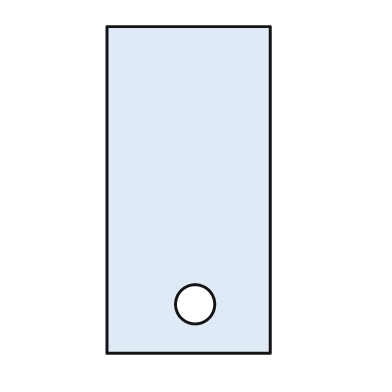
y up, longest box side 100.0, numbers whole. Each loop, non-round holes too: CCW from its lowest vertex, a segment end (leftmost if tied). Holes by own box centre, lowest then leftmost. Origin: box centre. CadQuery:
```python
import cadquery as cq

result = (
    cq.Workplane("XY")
    .moveTo(-25.0, -50.0)
    .lineTo(25.0, -50.0)
    .lineTo(25.0, 50.0)
    .lineTo(-25.0, 50.0)
    .close()
    .moveTo(2.0, -35.0)
    .circle(6.0)
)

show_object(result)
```